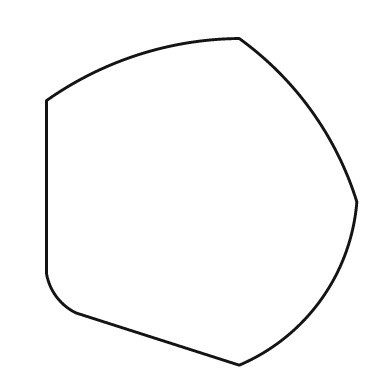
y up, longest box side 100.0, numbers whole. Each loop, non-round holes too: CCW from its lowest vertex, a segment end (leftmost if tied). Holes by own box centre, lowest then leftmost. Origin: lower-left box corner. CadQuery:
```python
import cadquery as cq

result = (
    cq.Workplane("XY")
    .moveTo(59.0, 0.0)
    .threePointArc((84.0, 20.0), (95.0, 50.0))
    .threePointArc((81.0, 78.0), (59.0, 100.0))
    .threePointArc((28.0, 95.0), (0.0, 81.0))
    .lineTo(0.0, 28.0)
    .threePointArc((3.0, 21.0), (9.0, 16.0))
    .close()
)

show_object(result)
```